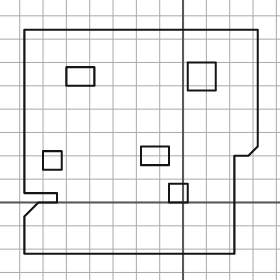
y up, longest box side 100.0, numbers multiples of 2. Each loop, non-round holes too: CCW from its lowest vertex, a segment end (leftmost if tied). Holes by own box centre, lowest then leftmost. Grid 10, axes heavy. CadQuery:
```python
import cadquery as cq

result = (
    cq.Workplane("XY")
    .moveTo(-68.0, -22.0)
    .lineTo(22.0, -22.0)
    .lineTo(22.0, 20.0)
    .lineTo(28.0, 20.0)
    .lineTo(32.0, 24.0)
    .lineTo(32.0, 74.0)
    .lineTo(-68.0, 74.0)
    .lineTo(-68.0, 4.0)
    .lineTo(-54.0, 4.0)
    .lineTo(-54.0, 0.0)
    .lineTo(-62.0, 0.0)
    .lineTo(-68.0, -6.0)
    .close()
    .moveTo(-6.0, 0.0)
    .lineTo(2.0, 0.0)
    .lineTo(2.0, 8.0)
    .lineTo(-6.0, 8.0)
    .close()
    .moveTo(-60.0, 14.0)
    .lineTo(-52.0, 14.0)
    .lineTo(-52.0, 22.0)
    .lineTo(-60.0, 22.0)
    .close()
    .moveTo(-18.0, 16.0)
    .lineTo(-6.0, 16.0)
    .lineTo(-6.0, 24.0)
    .lineTo(-18.0, 24.0)
    .close()
    .moveTo(-50.0, 50.0)
    .lineTo(-38.0, 50.0)
    .lineTo(-38.0, 58.0)
    .lineTo(-50.0, 58.0)
    .close()
    .moveTo(2.0, 48.0)
    .lineTo(14.0, 48.0)
    .lineTo(14.0, 60.0)
    .lineTo(2.0, 60.0)
    .close()
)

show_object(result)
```